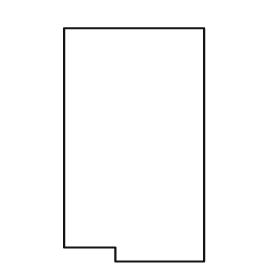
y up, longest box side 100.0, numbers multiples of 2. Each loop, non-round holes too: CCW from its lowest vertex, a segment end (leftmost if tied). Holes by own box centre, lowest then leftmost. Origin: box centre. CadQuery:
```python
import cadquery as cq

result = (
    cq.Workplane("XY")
    .moveTo(-8.0, -50.0)
    .lineTo(30.0, -50.0)
    .lineTo(30.0, 50.0)
    .lineTo(-30.0, 50.0)
    .lineTo(-30.0, -44.0)
    .lineTo(-8.0, -44.0)
    .close()
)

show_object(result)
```